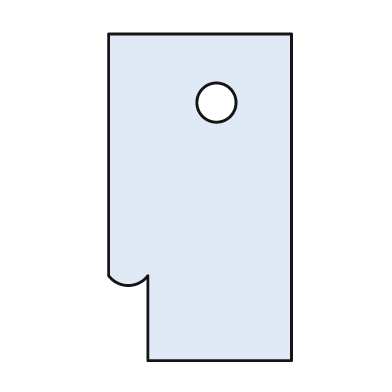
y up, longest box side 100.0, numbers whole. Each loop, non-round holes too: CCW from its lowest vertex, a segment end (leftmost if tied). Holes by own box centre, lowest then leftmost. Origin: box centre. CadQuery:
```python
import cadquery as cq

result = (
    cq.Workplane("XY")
    .moveTo(-16.0, -50.0)
    .lineTo(28.0, -50.0)
    .lineTo(28.0, 50.0)
    .lineTo(-28.0, 50.0)
    .lineTo(-28.0, -24.0)
    .threePointArc((-22.0, -27.0), (-16.0, -24.0))
    .close()
    .moveTo(5.0, 29.0)
    .circle(6.0)
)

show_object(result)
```